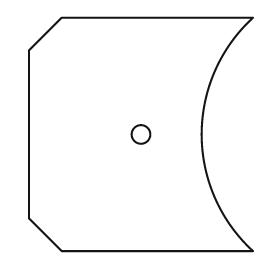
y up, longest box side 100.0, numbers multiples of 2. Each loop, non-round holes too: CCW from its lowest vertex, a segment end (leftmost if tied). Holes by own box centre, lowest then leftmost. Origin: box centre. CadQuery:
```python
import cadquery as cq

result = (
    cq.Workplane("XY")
    .moveTo(-34.0, -50.0)
    .lineTo(48.0, -50.0)
    .threePointArc((26.0, 0.0), (48.0, 50.0))
    .lineTo(-34.0, 50.0)
    .lineTo(-48.0, 36.0)
    .lineTo(-48.0, -36.0)
    .close()
    .moveTo(0.0, 0.0)
    .circle(4.0)
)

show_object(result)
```